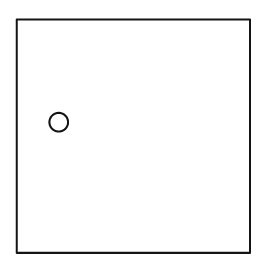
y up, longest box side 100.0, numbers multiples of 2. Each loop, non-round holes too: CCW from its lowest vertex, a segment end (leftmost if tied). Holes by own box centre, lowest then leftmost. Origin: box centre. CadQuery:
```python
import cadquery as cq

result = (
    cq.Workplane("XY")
    .moveTo(-50.0, -50.0)
    .lineTo(50.0, -50.0)
    .lineTo(50.0, 50.0)
    .lineTo(-50.0, 50.0)
    .close()
    .moveTo(-32.0, 6.0)
    .circle(4.0)
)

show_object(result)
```